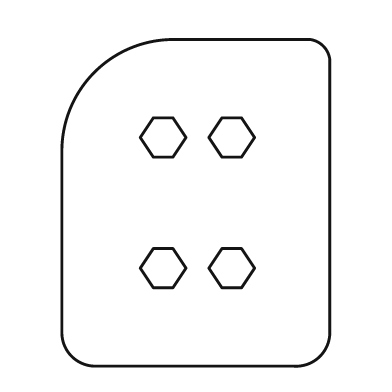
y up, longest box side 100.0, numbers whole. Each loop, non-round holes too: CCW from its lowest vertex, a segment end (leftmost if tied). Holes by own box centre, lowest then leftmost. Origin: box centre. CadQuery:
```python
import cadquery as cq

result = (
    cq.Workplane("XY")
    .moveTo(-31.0, -50.0)
    .lineTo(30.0, -50.0)
    .threePointArc((38.0, -47.0), (41.0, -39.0))
    .lineTo(41.0, 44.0)
    .threePointArc((39.0, 48.0), (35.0, 50.0))
    .lineTo(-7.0, 50.0)
    .threePointArc((-31.0, 40.0), (-41.0, 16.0))
    .lineTo(-41.0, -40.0)
    .threePointArc((-38.0, -47.0), (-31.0, -50.0))
    .close()
    .moveTo(-13.0, -26.0)
    .lineTo(-7.0, -26.0)
    .lineTo(-3.0, -20.0)
    .lineTo(-7.0, -14.0)
    .lineTo(-13.0, -14.0)
    .lineTo(-17.0, -20.0)
    .close()
    .moveTo(8.0, -26.0)
    .lineTo(14.0, -26.0)
    .lineTo(18.0, -20.0)
    .lineTo(14.0, -14.0)
    .lineTo(8.0, -14.0)
    .lineTo(4.0, -20.0)
    .close()
    .moveTo(-13.0, 14.0)
    .lineTo(-7.0, 14.0)
    .lineTo(-3.0, 20.0)
    .lineTo(-7.0, 26.0)
    .lineTo(-13.0, 26.0)
    .lineTo(-17.0, 20.0)
    .close()
    .moveTo(8.0, 14.0)
    .lineTo(14.0, 14.0)
    .lineTo(18.0, 20.0)
    .lineTo(14.0, 26.0)
    .lineTo(8.0, 26.0)
    .lineTo(4.0, 20.0)
    .close()
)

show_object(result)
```